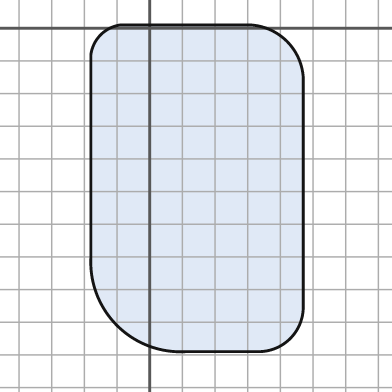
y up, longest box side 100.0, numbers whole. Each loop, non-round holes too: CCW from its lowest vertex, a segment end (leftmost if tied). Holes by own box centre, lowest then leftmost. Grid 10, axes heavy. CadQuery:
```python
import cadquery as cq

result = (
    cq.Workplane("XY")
    .moveTo(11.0, -99.0)
    .lineTo(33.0, -99.0)
    .threePointArc((43.0, -95.0), (47.0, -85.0))
    .lineTo(47.0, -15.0)
    .threePointArc((42.0, -4.0), (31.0, 1.0))
    .lineTo(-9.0, 1.0)
    .threePointArc((-15.0, -2.0), (-18.0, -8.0))
    .lineTo(-18.0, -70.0)
    .threePointArc((-10.0, -91.0), (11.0, -99.0))
    .close()
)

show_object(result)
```